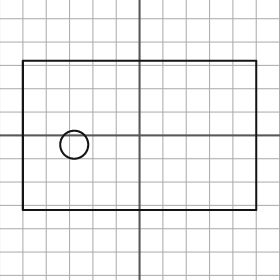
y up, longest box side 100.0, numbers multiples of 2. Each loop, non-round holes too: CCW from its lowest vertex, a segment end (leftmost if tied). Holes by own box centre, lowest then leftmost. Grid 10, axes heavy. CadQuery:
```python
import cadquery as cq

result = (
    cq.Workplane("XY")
    .moveTo(-50.0, -32.0)
    .lineTo(50.0, -32.0)
    .lineTo(50.0, 32.0)
    .lineTo(-50.0, 32.0)
    .close()
    .moveTo(-28.0, -4.0)
    .circle(6.0)
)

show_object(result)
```